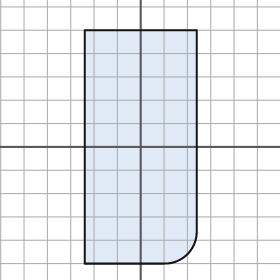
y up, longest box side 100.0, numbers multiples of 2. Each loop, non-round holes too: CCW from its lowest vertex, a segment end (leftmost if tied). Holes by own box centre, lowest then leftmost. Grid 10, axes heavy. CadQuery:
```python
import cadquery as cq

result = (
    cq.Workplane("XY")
    .moveTo(-24.0, -50.0)
    .lineTo(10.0, -50.0)
    .threePointArc((20.0, -46.0), (24.0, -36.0))
    .lineTo(24.0, 50.0)
    .lineTo(-24.0, 50.0)
    .close()
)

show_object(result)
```